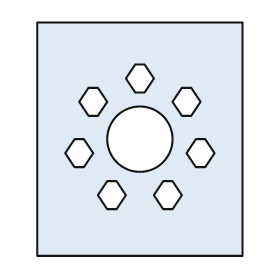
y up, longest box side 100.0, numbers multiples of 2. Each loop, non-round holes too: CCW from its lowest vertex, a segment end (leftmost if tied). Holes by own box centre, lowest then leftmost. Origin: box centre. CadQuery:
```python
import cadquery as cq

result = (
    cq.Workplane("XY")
    .moveTo(-44.0, -50.0)
    .lineTo(44.0, -50.0)
    .lineTo(44.0, 50.0)
    .lineTo(-44.0, 50.0)
    .close()
    .moveTo(-14.0, -30.0)
    .lineTo(-10.0, -30.0)
    .lineTo(-6.0, -24.0)
    .lineTo(-10.0, -18.0)
    .lineTo(-14.0, -18.0)
    .lineTo(-18.0, -24.0)
    .close()
    .moveTo(10.0, -30.0)
    .lineTo(14.0, -30.0)
    .lineTo(18.0, -24.0)
    .lineTo(14.0, -18.0)
    .lineTo(10.0, -18.0)
    .lineTo(6.0, -24.0)
    .close()
    .moveTo(-28.0, -12.0)
    .lineTo(-24.0, -12.0)
    .lineTo(-20.0, -6.0)
    .lineTo(-24.0, 0.0)
    .lineTo(-28.0, 0.0)
    .lineTo(-32.0, -6.0)
    .close()
    .moveTo(24.0, -12.0)
    .lineTo(28.0, -12.0)
    .lineTo(32.0, -6.0)
    .lineTo(28.0, 0.0)
    .lineTo(24.0, 0.0)
    .lineTo(20.0, -6.0)
    .close()
    .moveTo(0.0, 0.0)
    .circle(14.0)
    .moveTo(-22.0, 10.0)
    .lineTo(-18.0, 10.0)
    .lineTo(-14.0, 16.0)
    .lineTo(-18.0, 22.0)
    .lineTo(-22.0, 22.0)
    .lineTo(-26.0, 16.0)
    .close()
    .moveTo(18.0, 10.0)
    .lineTo(22.0, 10.0)
    .lineTo(26.0, 16.0)
    .lineTo(22.0, 22.0)
    .lineTo(18.0, 22.0)
    .lineTo(14.0, 16.0)
    .close()
    .moveTo(-2.0, 20.0)
    .lineTo(2.0, 20.0)
    .lineTo(6.0, 26.0)
    .lineTo(2.0, 32.0)
    .lineTo(-2.0, 32.0)
    .lineTo(-6.0, 26.0)
    .close()
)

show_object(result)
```